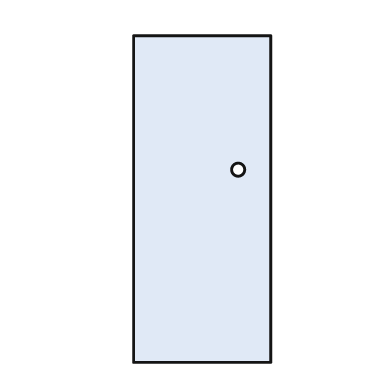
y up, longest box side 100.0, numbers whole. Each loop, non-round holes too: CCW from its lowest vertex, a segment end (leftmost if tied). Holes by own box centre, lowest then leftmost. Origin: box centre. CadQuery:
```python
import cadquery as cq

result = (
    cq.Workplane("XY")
    .moveTo(-21.0, -50.0)
    .lineTo(21.0, -50.0)
    .lineTo(21.0, 50.0)
    .lineTo(-21.0, 50.0)
    .close()
    .moveTo(11.0, 9.0)
    .circle(2.0)
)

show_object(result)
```